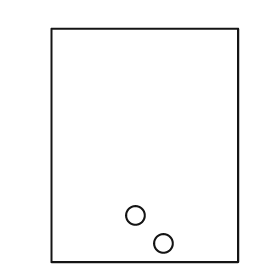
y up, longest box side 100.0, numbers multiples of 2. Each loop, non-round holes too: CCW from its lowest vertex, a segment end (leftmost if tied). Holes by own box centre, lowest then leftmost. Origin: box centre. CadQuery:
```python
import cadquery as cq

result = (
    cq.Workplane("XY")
    .moveTo(-40.0, -50.0)
    .lineTo(40.0, -50.0)
    .lineTo(40.0, 50.0)
    .lineTo(-40.0, 50.0)
    .close()
    .moveTo(8.0, -42.0)
    .circle(4.0)
    .moveTo(-4.0, -30.0)
    .circle(4.0)
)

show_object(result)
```